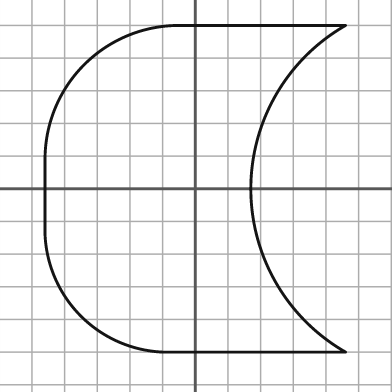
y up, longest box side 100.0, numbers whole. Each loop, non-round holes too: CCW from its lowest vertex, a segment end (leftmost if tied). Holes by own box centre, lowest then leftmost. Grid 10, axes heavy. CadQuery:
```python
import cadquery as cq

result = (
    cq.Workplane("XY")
    .moveTo(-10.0, -50.0)
    .lineTo(46.0, -50.0)
    .threePointArc((17.0, 0.0), (46.0, 50.0))
    .lineTo(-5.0, 50.0)
    .threePointArc((-34.0, 38.0), (-46.0, 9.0))
    .lineTo(-46.0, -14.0)
    .threePointArc((-35.0, -39.0), (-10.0, -50.0))
    .close()
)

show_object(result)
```